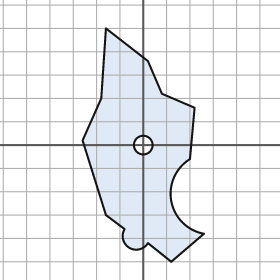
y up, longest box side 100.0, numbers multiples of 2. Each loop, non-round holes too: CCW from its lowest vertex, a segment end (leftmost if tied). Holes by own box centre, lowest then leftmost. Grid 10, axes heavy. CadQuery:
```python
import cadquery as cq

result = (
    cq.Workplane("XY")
    .moveTo(12.0, -50.0)
    .lineTo(26.0, -38.0)
    .threePointArc((12.0, -24.0), (20.0, -6.0))
    .lineTo(22.0, 16.0)
    .lineTo(8.0, 22.0)
    .lineTo(2.0, 36.0)
    .lineTo(-16.0, 50.0)
    .lineTo(-18.0, 20.0)
    .lineTo(-26.0, 2.0)
    .lineTo(-16.0, -30.0)
    .lineTo(-8.0, -36.0)
    .threePointArc((-6.0, -44.0), (2.0, -42.0))
    .close()
    .moveTo(0.0, 0.0)
    .circle(4.0)
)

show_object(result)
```